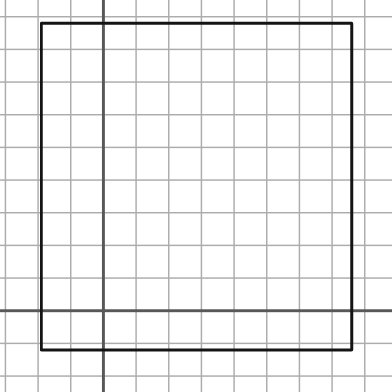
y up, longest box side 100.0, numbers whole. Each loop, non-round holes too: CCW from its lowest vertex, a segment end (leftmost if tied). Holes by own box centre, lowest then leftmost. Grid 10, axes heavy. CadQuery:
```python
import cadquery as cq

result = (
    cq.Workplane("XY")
    .moveTo(-19.0, -12.0)
    .lineTo(76.0, -12.0)
    .lineTo(76.0, 88.0)
    .lineTo(-19.0, 88.0)
    .close()
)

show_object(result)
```